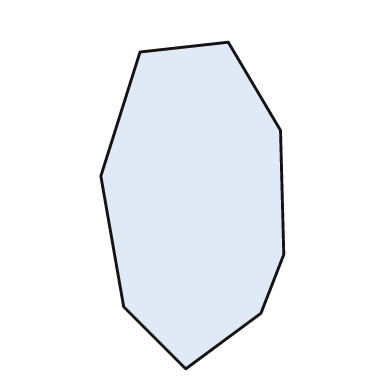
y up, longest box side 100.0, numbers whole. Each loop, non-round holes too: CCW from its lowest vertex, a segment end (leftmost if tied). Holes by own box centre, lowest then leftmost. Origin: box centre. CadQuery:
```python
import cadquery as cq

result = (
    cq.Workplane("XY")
    .moveTo(-2.0, -50.0)
    .lineTo(21.0, -33.0)
    .lineTo(28.0, -15.0)
    .lineTo(27.0, 23.0)
    .lineTo(11.0, 50.0)
    .lineTo(-16.0, 47.0)
    .lineTo(-28.0, 9.0)
    .lineTo(-21.0, -31.0)
    .close()
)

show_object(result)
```